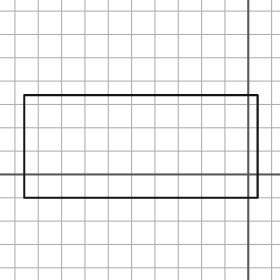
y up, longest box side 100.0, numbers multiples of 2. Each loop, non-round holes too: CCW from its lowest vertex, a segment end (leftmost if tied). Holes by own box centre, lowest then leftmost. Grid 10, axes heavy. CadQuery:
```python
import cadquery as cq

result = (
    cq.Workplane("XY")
    .moveTo(-96.0, -10.0)
    .lineTo(4.0, -10.0)
    .lineTo(4.0, 34.0)
    .lineTo(-96.0, 34.0)
    .close()
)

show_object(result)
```